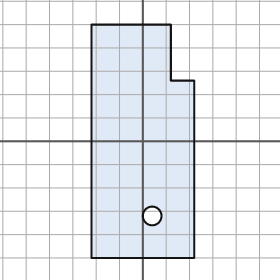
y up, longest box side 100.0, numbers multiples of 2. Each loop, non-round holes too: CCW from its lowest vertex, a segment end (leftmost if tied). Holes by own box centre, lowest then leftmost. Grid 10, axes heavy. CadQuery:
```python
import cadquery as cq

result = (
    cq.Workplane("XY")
    .moveTo(-22.0, -50.0)
    .lineTo(22.0, -50.0)
    .lineTo(22.0, 26.0)
    .lineTo(12.0, 26.0)
    .lineTo(12.0, 50.0)
    .lineTo(-22.0, 50.0)
    .close()
    .moveTo(4.0, -32.0)
    .circle(4.0)
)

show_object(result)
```